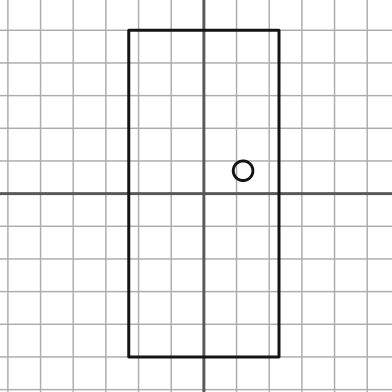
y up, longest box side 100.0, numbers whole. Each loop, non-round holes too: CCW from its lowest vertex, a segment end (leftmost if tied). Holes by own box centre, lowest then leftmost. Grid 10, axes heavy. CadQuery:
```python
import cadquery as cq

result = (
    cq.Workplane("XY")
    .moveTo(-23.0, -50.0)
    .lineTo(23.0, -50.0)
    .lineTo(23.0, 50.0)
    .lineTo(-23.0, 50.0)
    .close()
    .moveTo(12.0, 7.0)
    .circle(3.0)
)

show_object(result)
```